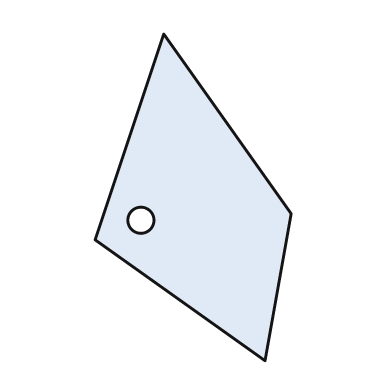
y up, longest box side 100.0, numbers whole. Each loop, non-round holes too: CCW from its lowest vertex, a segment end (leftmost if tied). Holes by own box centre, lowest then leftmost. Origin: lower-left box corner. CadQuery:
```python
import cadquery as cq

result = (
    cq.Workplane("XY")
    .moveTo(52.0, 0.0)
    .lineTo(60.0, 45.0)
    .lineTo(21.0, 100.0)
    .lineTo(0.0, 37.0)
    .close()
    .moveTo(14.0, 43.0)
    .circle(4.0)
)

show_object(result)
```